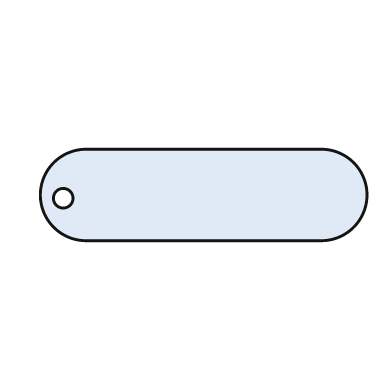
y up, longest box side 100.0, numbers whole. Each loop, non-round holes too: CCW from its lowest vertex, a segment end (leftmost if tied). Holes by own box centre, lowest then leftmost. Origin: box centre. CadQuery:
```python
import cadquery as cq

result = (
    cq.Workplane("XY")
    .moveTo(-36.0, -14.0)
    .lineTo(36.0, -14.0)
    .threePointArc((50.0, 0.0), (36.0, 14.0))
    .lineTo(-36.0, 14.0)
    .threePointArc((-50.0, 0.0), (-36.0, -14.0))
    .close()
    .moveTo(-43.0, -1.0)
    .circle(3.0)
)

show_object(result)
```